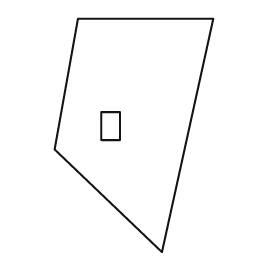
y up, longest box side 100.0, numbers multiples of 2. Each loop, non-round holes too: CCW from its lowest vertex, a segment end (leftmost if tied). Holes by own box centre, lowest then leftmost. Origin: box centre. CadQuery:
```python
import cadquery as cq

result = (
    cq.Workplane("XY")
    .moveTo(12.0, -50.0)
    .lineTo(34.0, 50.0)
    .lineTo(-24.0, 50.0)
    .lineTo(-34.0, -6.0)
    .close()
    .moveTo(-14.0, -2.0)
    .lineTo(-6.0, -2.0)
    .lineTo(-6.0, 10.0)
    .lineTo(-14.0, 10.0)
    .close()
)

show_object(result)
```